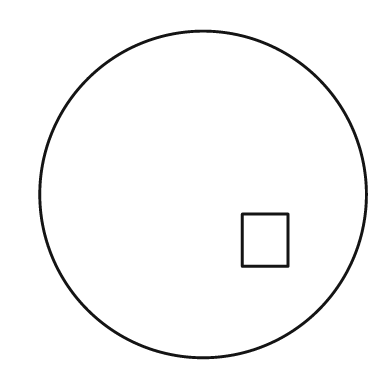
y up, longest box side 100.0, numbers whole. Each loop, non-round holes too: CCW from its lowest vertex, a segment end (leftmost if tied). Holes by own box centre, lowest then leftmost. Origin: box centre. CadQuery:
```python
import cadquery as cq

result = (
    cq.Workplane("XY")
    .moveTo(0.0, 0.0)
    .circle(50.0)
    .moveTo(12.0, -22.0)
    .lineTo(26.0, -22.0)
    .lineTo(26.0, -6.0)
    .lineTo(12.0, -6.0)
    .close()
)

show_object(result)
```